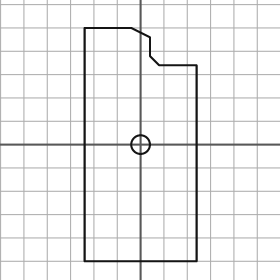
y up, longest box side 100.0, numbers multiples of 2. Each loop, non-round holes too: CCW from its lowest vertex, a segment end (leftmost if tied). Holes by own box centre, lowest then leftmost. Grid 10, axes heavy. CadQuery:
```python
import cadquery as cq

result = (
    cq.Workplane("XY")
    .moveTo(-24.0, -50.0)
    .lineTo(24.0, -50.0)
    .lineTo(24.0, 34.0)
    .lineTo(8.0, 34.0)
    .lineTo(4.0, 38.0)
    .lineTo(4.0, 46.0)
    .lineTo(-4.0, 50.0)
    .lineTo(-24.0, 50.0)
    .close()
    .moveTo(0.0, 0.0)
    .circle(4.0)
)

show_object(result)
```